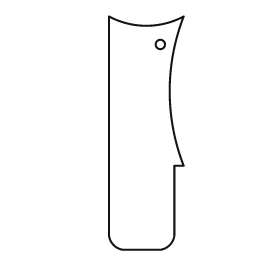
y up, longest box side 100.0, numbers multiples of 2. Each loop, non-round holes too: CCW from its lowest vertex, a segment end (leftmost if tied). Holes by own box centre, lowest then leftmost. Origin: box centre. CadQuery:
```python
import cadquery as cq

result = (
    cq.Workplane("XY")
    .moveTo(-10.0, -50.0)
    .lineTo(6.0, -50.0)
    .threePointArc((10.0, -48.0), (12.0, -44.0))
    .lineTo(12.0, -14.0)
    .lineTo(16.0, -14.0)
    .threePointArc((10.0, 18.0), (16.0, 50.0))
    .threePointArc((0.0, 46.0), (-16.0, 50.0))
    .lineTo(-16.0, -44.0)
    .threePointArc((-14.0, -48.0), (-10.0, -50.0))
    .close()
    .moveTo(6.0, 38.0)
    .circle(2.0)
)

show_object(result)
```